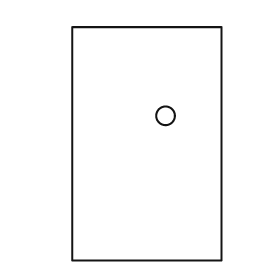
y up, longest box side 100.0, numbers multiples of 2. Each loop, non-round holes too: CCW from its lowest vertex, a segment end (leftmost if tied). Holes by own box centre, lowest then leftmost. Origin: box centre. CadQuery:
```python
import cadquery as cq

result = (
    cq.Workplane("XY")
    .moveTo(-32.0, -50.0)
    .lineTo(32.0, -50.0)
    .lineTo(32.0, 50.0)
    .lineTo(-32.0, 50.0)
    .close()
    .moveTo(8.0, 12.0)
    .circle(4.0)
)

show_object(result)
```